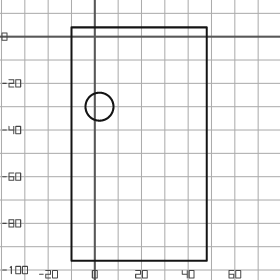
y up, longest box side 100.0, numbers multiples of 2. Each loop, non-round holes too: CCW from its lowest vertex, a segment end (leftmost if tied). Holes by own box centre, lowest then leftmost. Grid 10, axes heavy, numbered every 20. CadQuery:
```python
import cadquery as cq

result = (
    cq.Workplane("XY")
    .moveTo(-10.0, -96.0)
    .lineTo(48.0, -96.0)
    .lineTo(48.0, 4.0)
    .lineTo(-10.0, 4.0)
    .close()
    .moveTo(2.0, -30.0)
    .circle(6.0)
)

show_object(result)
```